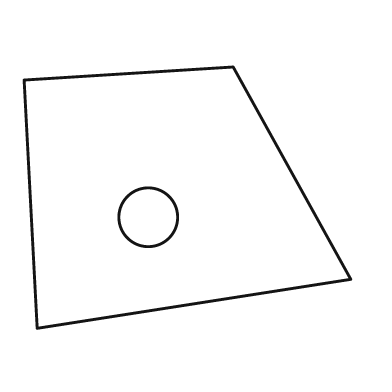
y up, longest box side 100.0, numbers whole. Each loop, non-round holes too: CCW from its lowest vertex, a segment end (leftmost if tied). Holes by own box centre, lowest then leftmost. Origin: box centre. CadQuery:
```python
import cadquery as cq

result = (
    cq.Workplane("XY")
    .moveTo(-46.0, -40.0)
    .lineTo(50.0, -25.0)
    .lineTo(14.0, 40.0)
    .lineTo(-50.0, 36.0)
    .close()
    .moveTo(-12.0, -6.0)
    .circle(9.0)
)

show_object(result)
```